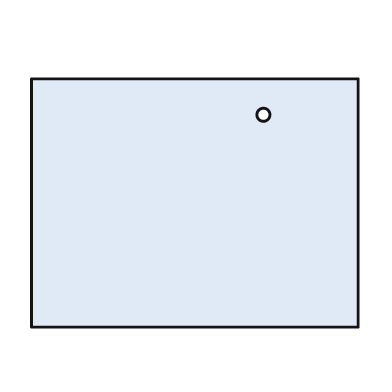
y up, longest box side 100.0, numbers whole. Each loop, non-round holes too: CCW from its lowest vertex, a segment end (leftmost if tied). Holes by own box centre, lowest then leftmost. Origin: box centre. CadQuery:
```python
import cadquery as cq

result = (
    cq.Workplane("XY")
    .moveTo(-50.0, -38.0)
    .lineTo(50.0, -38.0)
    .lineTo(50.0, 38.0)
    .lineTo(-50.0, 38.0)
    .close()
    .moveTo(21.0, 27.0)
    .circle(2.0)
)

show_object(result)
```